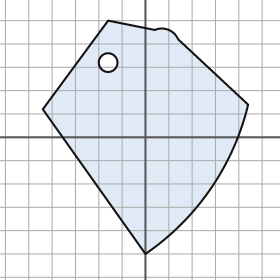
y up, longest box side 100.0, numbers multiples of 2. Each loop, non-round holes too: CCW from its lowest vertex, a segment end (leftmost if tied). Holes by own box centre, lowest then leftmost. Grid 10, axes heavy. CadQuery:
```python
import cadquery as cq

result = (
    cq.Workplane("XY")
    .moveTo(0.0, -50.0)
    .threePointArc((28.0, -22.0), (44.0, 14.0))
    .lineTo(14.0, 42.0)
    .threePointArc((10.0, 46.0), (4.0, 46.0))
    .lineTo(-16.0, 50.0)
    .lineTo(-44.0, 12.0)
    .close()
    .moveTo(-16.0, 32.0)
    .circle(4.0)
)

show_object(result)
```